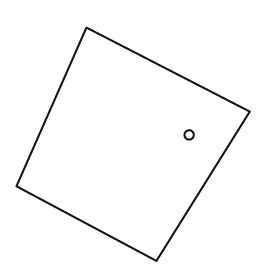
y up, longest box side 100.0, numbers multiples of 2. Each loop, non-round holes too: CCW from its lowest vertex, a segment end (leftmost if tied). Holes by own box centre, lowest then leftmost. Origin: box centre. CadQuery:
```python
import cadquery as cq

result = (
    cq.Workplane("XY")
    .moveTo(10.0, -50.0)
    .lineTo(50.0, 14.0)
    .lineTo(-20.0, 50.0)
    .lineTo(-50.0, -18.0)
    .close()
    .moveTo(24.0, 4.0)
    .circle(2.0)
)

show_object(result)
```